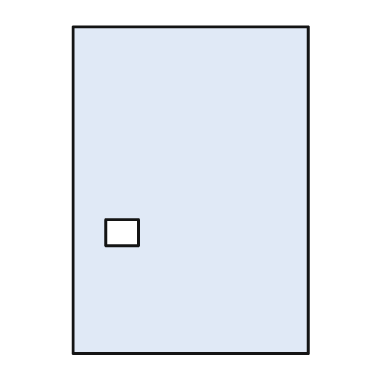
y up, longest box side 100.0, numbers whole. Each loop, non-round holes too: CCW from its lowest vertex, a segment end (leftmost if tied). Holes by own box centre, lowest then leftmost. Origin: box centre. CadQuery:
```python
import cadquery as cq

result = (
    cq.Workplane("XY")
    .moveTo(-36.0, -50.0)
    .lineTo(36.0, -50.0)
    .lineTo(36.0, 50.0)
    .lineTo(-36.0, 50.0)
    .close()
    .moveTo(-26.0, -17.0)
    .lineTo(-16.0, -17.0)
    .lineTo(-16.0, -9.0)
    .lineTo(-26.0, -9.0)
    .close()
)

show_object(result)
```